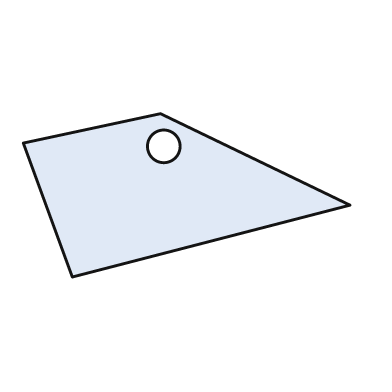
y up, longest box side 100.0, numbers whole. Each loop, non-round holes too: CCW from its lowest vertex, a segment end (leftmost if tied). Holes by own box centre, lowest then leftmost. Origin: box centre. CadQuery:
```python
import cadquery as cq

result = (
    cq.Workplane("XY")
    .moveTo(-35.0, -25.0)
    .lineTo(50.0, -3.0)
    .lineTo(-8.0, 25.0)
    .lineTo(-50.0, 16.0)
    .close()
    .moveTo(-7.0, 15.0)
    .circle(5.0)
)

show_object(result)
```